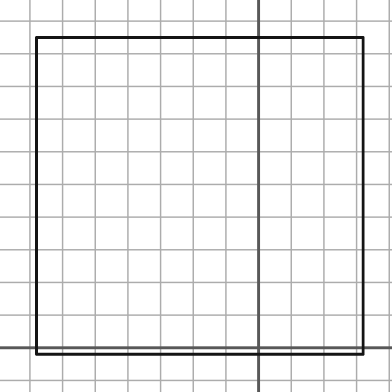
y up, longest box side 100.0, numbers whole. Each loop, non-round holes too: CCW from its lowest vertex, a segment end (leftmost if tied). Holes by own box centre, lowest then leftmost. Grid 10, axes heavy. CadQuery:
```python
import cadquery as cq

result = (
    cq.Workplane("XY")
    .moveTo(-68.0, -2.0)
    .lineTo(32.0, -2.0)
    .lineTo(32.0, 95.0)
    .lineTo(-68.0, 95.0)
    .close()
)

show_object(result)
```